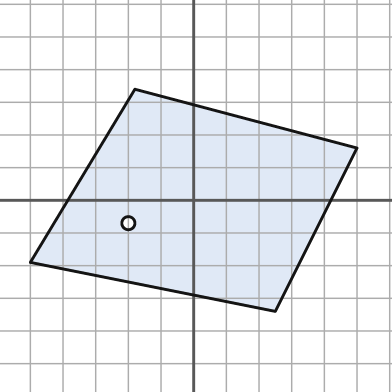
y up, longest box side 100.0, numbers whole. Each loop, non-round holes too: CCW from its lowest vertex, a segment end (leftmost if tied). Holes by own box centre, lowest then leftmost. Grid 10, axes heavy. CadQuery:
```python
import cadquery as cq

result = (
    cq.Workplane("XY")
    .moveTo(25.0, -34.0)
    .lineTo(50.0, 16.0)
    .lineTo(-18.0, 34.0)
    .lineTo(-50.0, -19.0)
    .close()
    .moveTo(-20.0, -7.0)
    .circle(2.0)
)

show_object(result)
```